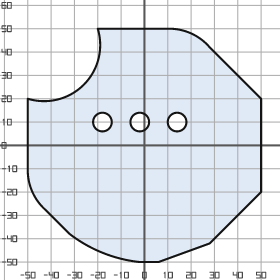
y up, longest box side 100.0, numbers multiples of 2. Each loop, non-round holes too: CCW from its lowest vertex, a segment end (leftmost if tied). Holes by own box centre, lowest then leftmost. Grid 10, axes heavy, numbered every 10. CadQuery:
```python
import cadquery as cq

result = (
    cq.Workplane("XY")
    .moveTo(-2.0, -50.0)
    .lineTo(6.0, -50.0)
    .lineTo(28.0, -42.0)
    .lineTo(50.0, -20.0)
    .lineTo(50.0, 20.0)
    .lineTo(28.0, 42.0)
    .threePointArc((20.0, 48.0), (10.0, 50.0))
    .lineTo(-20.0, 50.0)
    .threePointArc((-26.0, 26.0), (-50.0, 20.0))
    .lineTo(-50.0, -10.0)
    .threePointArc((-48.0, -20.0), (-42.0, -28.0))
    .lineTo(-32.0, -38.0)
    .threePointArc((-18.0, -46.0), (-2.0, -50.0))
    .close()
    .moveTo(-18.0, 10.0)
    .circle(4.0)
    .moveTo(-2.0, 10.0)
    .circle(4.0)
    .moveTo(14.0, 10.0)
    .circle(4.0)
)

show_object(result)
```